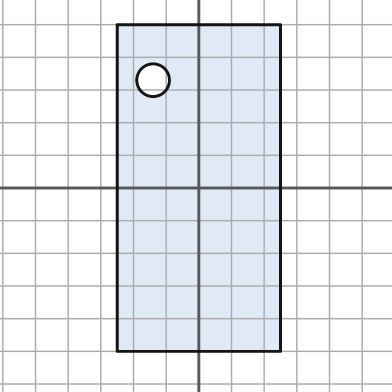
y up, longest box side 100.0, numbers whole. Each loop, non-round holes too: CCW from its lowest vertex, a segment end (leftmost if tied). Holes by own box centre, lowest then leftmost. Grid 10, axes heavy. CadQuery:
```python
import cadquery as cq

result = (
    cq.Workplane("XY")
    .moveTo(-25.0, -50.0)
    .lineTo(25.0, -50.0)
    .lineTo(25.0, 50.0)
    .lineTo(-25.0, 50.0)
    .close()
    .moveTo(-14.0, 33.0)
    .circle(5.0)
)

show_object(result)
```